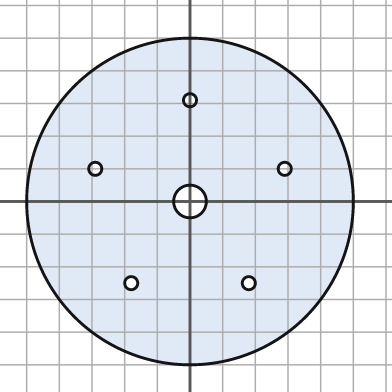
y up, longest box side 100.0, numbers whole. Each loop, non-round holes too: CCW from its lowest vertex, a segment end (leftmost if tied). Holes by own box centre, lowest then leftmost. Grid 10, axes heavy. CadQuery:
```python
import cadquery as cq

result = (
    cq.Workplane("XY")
    .moveTo(0.0, 0.0)
    .circle(50.0)
    .moveTo(-18.0, -25.0)
    .circle(2.0)
    .moveTo(18.0, -25.0)
    .circle(2.0)
    .moveTo(0.0, 0.0)
    .circle(5.0)
    .moveTo(-29.0, 10.0)
    .circle(2.0)
    .moveTo(29.0, 10.0)
    .circle(2.0)
    .moveTo(0.0, 31.0)
    .circle(2.0)
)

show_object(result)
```